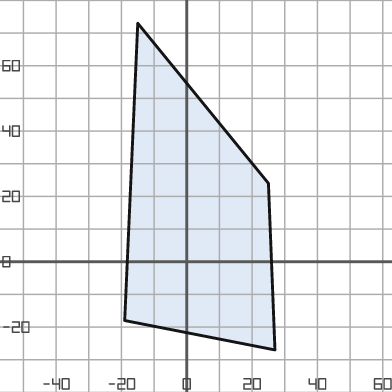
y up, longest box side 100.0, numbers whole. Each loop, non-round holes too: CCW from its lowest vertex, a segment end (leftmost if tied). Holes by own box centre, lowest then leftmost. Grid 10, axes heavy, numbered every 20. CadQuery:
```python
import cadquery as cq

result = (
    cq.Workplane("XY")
    .moveTo(27.0, -27.0)
    .lineTo(25.0, 24.0)
    .lineTo(-15.0, 73.0)
    .lineTo(-19.0, -18.0)
    .close()
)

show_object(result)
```